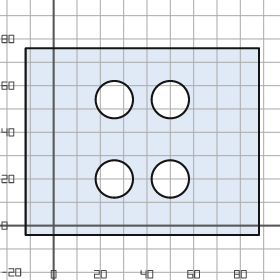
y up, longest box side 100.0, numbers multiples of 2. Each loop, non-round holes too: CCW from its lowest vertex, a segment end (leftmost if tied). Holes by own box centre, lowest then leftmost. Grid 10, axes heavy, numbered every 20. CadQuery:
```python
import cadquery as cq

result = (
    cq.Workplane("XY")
    .moveTo(-12.0, -4.0)
    .lineTo(88.0, -4.0)
    .lineTo(88.0, 76.0)
    .lineTo(-12.0, 76.0)
    .close()
    .moveTo(26.0, 20.0)
    .circle(8.0)
    .moveTo(50.0, 20.0)
    .circle(8.0)
    .moveTo(26.0, 54.0)
    .circle(8.0)
    .moveTo(50.0, 54.0)
    .circle(8.0)
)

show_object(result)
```